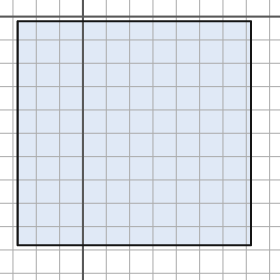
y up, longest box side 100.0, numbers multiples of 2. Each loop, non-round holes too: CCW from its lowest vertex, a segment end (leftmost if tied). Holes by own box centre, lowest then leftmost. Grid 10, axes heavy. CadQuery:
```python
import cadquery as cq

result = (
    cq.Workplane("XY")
    .moveTo(-28.0, -98.0)
    .lineTo(72.0, -98.0)
    .lineTo(72.0, -2.0)
    .lineTo(-28.0, -2.0)
    .close()
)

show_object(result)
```